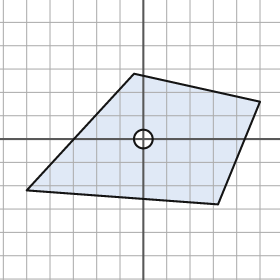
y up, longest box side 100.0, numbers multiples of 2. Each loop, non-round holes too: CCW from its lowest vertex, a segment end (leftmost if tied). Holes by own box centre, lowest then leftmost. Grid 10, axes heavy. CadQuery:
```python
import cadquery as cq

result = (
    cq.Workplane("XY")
    .moveTo(32.0, -28.0)
    .lineTo(50.0, 16.0)
    .lineTo(-4.0, 28.0)
    .lineTo(-50.0, -22.0)
    .close()
    .moveTo(0.0, 0.0)
    .circle(4.0)
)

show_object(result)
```